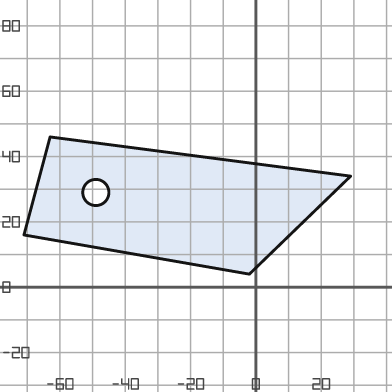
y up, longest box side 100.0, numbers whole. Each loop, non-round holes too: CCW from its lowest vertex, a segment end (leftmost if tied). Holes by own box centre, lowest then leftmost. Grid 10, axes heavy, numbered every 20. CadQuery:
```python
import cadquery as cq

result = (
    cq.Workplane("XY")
    .moveTo(-2.0, 4.0)
    .lineTo(29.0, 34.0)
    .lineTo(-63.0, 46.0)
    .lineTo(-71.0, 16.0)
    .close()
    .moveTo(-49.0, 29.0)
    .circle(4.0)
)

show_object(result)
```